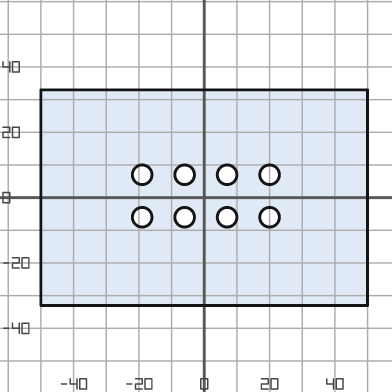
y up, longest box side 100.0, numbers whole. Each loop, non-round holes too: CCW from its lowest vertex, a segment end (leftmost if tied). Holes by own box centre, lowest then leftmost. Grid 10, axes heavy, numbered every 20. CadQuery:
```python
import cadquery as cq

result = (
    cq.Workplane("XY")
    .moveTo(-50.0, -33.0)
    .lineTo(50.0, -33.0)
    .lineTo(50.0, 33.0)
    .lineTo(-50.0, 33.0)
    .close()
    .moveTo(-19.0, -6.0)
    .circle(3.0)
    .moveTo(-6.0, -6.0)
    .circle(3.0)
    .moveTo(7.0, -6.0)
    .circle(3.0)
    .moveTo(20.0, -6.0)
    .circle(3.0)
    .moveTo(-19.0, 7.0)
    .circle(3.0)
    .moveTo(-6.0, 7.0)
    .circle(3.0)
    .moveTo(7.0, 7.0)
    .circle(3.0)
    .moveTo(20.0, 7.0)
    .circle(3.0)
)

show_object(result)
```